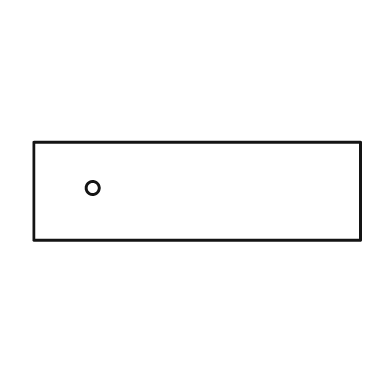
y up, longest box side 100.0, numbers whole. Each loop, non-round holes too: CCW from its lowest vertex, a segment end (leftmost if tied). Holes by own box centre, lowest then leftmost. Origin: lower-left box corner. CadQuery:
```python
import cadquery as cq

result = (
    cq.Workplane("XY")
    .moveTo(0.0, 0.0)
    .lineTo(100.0, 0.0)
    .lineTo(100.0, 30.0)
    .lineTo(0.0, 30.0)
    .close()
    .moveTo(18.0, 16.0)
    .circle(2.0)
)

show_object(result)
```